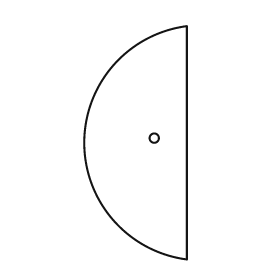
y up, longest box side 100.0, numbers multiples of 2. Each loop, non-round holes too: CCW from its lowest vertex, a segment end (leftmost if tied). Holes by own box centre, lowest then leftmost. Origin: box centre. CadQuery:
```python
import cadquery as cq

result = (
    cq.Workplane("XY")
    .moveTo(22.0, -50.0)
    .lineTo(22.0, 50.0)
    .threePointArc((-22.0, 0.0), (22.0, -50.0))
    .close()
    .moveTo(8.0, 2.0)
    .circle(2.0)
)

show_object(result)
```